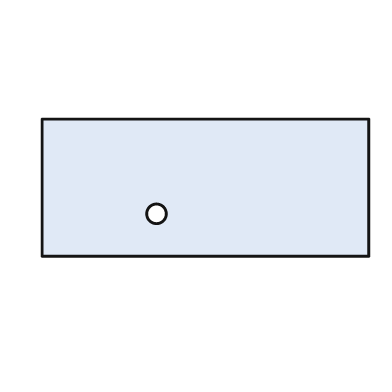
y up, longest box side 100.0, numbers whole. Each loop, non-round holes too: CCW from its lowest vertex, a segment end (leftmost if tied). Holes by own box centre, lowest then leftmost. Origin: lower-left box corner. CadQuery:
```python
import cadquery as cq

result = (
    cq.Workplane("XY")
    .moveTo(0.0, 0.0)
    .lineTo(100.0, 0.0)
    .lineTo(100.0, 42.0)
    .lineTo(0.0, 42.0)
    .close()
    .moveTo(35.0, 13.0)
    .circle(3.0)
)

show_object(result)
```